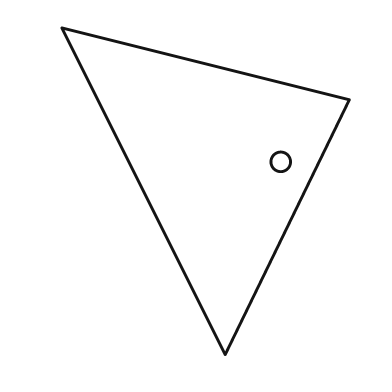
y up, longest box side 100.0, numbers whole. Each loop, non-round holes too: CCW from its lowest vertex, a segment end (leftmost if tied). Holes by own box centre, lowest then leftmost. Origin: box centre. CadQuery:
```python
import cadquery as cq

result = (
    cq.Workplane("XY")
    .moveTo(6.0, -50.0)
    .lineTo(44.0, 28.0)
    .lineTo(-44.0, 50.0)
    .close()
    .moveTo(23.0, 9.0)
    .circle(3.0)
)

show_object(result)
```